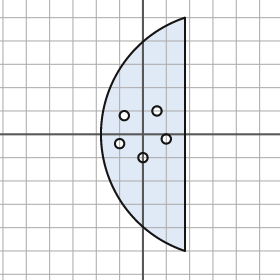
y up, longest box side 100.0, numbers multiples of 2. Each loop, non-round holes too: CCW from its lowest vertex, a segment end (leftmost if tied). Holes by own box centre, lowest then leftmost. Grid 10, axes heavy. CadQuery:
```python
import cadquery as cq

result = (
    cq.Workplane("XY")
    .moveTo(18.0, -50.0)
    .lineTo(18.0, 50.0)
    .threePointArc((-18.0, 0.0), (18.0, -50.0))
    .close()
    .moveTo(0.0, -10.0)
    .circle(2.0)
    .moveTo(-10.0, -4.0)
    .circle(2.0)
    .moveTo(10.0, -2.0)
    .circle(2.0)
    .moveTo(-8.0, 8.0)
    .circle(2.0)
    .moveTo(6.0, 10.0)
    .circle(2.0)
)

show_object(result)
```